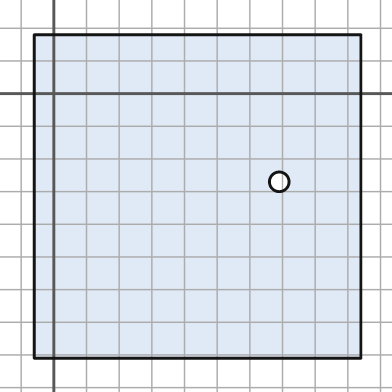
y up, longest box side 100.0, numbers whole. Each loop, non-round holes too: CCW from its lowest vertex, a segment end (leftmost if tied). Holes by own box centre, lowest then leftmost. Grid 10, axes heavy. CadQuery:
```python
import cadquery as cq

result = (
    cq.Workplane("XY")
    .moveTo(-6.0, -81.0)
    .lineTo(94.0, -81.0)
    .lineTo(94.0, 18.0)
    .lineTo(-6.0, 18.0)
    .close()
    .moveTo(69.0, -27.0)
    .circle(3.0)
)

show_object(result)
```